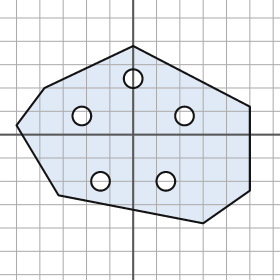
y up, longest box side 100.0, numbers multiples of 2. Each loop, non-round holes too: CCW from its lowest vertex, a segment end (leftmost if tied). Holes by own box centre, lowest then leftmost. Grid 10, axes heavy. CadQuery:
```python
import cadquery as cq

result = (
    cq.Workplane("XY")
    .moveTo(30.0, -38.0)
    .lineTo(50.0, -24.0)
    .lineTo(50.0, 12.0)
    .lineTo(0.0, 38.0)
    .lineTo(-38.0, 20.0)
    .lineTo(-50.0, 4.0)
    .lineTo(-32.0, -26.0)
    .close()
    .moveTo(-14.0, -20.0)
    .circle(4.0)
    .moveTo(14.0, -20.0)
    .circle(4.0)
    .moveTo(-22.0, 8.0)
    .circle(4.0)
    .moveTo(22.0, 8.0)
    .circle(4.0)
    .moveTo(0.0, 24.0)
    .circle(4.0)
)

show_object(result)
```